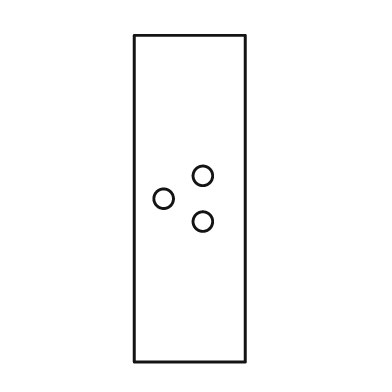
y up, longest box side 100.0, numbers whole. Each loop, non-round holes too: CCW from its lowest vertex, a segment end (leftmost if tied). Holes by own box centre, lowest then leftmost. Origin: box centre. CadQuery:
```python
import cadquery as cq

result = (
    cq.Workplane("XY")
    .moveTo(-17.0, -50.0)
    .lineTo(17.0, -50.0)
    .lineTo(17.0, 50.0)
    .lineTo(-17.0, 50.0)
    .close()
    .moveTo(4.0, -7.0)
    .circle(3.0)
    .moveTo(-8.0, 0.0)
    .circle(3.0)
    .moveTo(4.0, 7.0)
    .circle(3.0)
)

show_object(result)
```